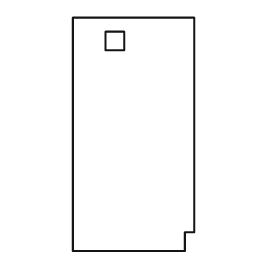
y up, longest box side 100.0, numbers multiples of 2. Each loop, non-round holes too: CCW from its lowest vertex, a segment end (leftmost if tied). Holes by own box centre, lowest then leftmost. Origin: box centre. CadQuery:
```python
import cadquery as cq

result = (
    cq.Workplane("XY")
    .moveTo(-26.0, -50.0)
    .lineTo(22.0, -50.0)
    .lineTo(22.0, -42.0)
    .lineTo(26.0, -42.0)
    .lineTo(26.0, 50.0)
    .lineTo(-26.0, 50.0)
    .close()
    .moveTo(-12.0, 36.0)
    .lineTo(-4.0, 36.0)
    .lineTo(-4.0, 44.0)
    .lineTo(-12.0, 44.0)
    .close()
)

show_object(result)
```